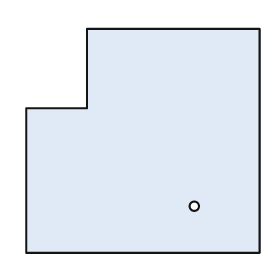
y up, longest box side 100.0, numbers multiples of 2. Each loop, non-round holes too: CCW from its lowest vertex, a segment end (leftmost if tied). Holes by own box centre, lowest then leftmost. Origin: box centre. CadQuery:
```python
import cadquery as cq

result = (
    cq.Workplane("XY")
    .moveTo(-50.0, -48.0)
    .lineTo(50.0, -48.0)
    .lineTo(50.0, 48.0)
    .lineTo(-24.0, 48.0)
    .lineTo(-24.0, 14.0)
    .lineTo(-50.0, 14.0)
    .close()
    .moveTo(22.0, -28.0)
    .circle(2.0)
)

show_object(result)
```